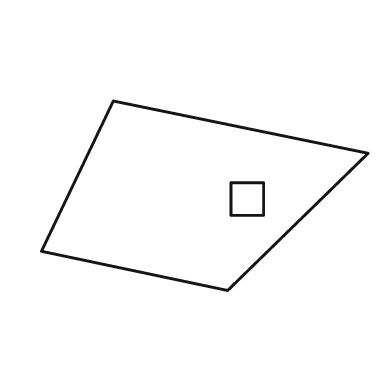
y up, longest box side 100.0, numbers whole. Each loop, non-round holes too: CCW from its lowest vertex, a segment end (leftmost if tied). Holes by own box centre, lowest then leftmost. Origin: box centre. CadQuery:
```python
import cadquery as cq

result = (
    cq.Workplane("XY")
    .moveTo(7.0, -29.0)
    .lineTo(50.0, 13.0)
    .lineTo(-28.0, 29.0)
    .lineTo(-50.0, -17.0)
    .close()
    .moveTo(8.0, -6.0)
    .lineTo(18.0, -6.0)
    .lineTo(18.0, 4.0)
    .lineTo(8.0, 4.0)
    .close()
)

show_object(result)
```